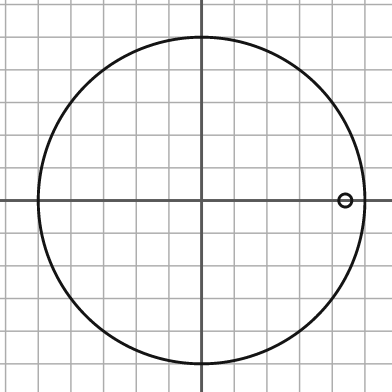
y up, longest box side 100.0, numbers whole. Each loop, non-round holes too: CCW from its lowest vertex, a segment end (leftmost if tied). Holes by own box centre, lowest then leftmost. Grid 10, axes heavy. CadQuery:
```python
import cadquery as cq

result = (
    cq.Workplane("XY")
    .moveTo(0.0, 0.0)
    .circle(50.0)
    .moveTo(44.0, 0.0)
    .circle(2.0)
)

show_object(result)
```